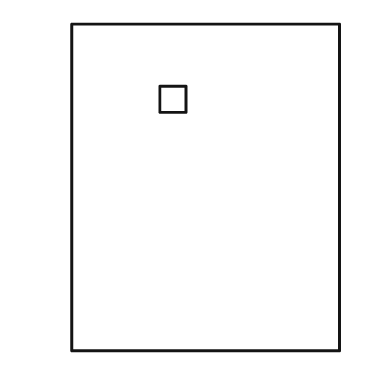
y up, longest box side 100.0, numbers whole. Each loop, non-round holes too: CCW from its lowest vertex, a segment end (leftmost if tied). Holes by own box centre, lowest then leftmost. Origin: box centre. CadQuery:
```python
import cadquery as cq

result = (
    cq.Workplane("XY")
    .moveTo(-41.0, -50.0)
    .lineTo(41.0, -50.0)
    .lineTo(41.0, 50.0)
    .lineTo(-41.0, 50.0)
    .close()
    .moveTo(-14.0, 23.0)
    .lineTo(-6.0, 23.0)
    .lineTo(-6.0, 31.0)
    .lineTo(-14.0, 31.0)
    .close()
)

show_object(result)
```